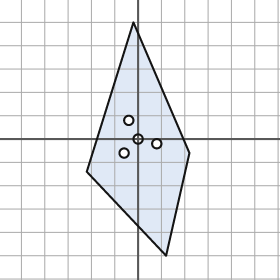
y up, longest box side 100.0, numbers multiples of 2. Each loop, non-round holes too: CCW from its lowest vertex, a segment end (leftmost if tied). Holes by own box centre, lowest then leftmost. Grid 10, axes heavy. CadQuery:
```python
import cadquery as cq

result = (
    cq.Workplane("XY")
    .moveTo(12.0, -50.0)
    .lineTo(22.0, -6.0)
    .lineTo(-2.0, 50.0)
    .lineTo(-22.0, -14.0)
    .close()
    .moveTo(-6.0, -6.0)
    .circle(2.0)
    .moveTo(8.0, -2.0)
    .circle(2.0)
    .moveTo(0.0, 0.0)
    .circle(2.0)
    .moveTo(-4.0, 8.0)
    .circle(2.0)
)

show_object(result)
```